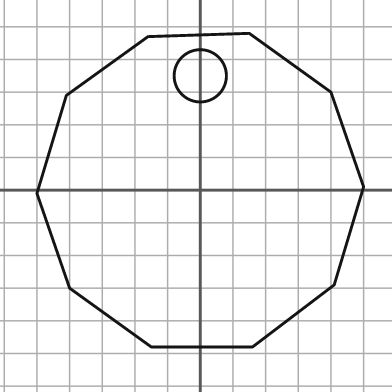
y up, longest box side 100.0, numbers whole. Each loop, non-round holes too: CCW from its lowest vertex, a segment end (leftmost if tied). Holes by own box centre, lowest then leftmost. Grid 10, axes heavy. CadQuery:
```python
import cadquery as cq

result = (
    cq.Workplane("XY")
    .moveTo(-15.0, -48.0)
    .lineTo(16.0, -48.0)
    .lineTo(41.0, -29.0)
    .lineTo(50.0, 1.0)
    .lineTo(40.0, 30.0)
    .lineTo(15.0, 48.0)
    .lineTo(-16.0, 47.0)
    .lineTo(-41.0, 29.0)
    .lineTo(-50.0, -1.0)
    .lineTo(-40.0, -30.0)
    .close()
    .moveTo(0.0, 35.0)
    .circle(8.0)
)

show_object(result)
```